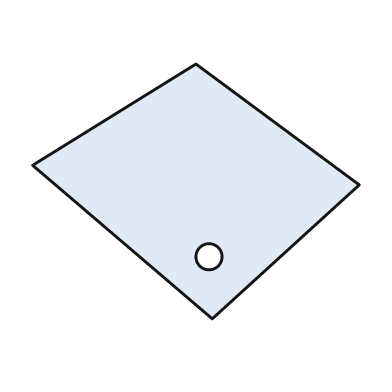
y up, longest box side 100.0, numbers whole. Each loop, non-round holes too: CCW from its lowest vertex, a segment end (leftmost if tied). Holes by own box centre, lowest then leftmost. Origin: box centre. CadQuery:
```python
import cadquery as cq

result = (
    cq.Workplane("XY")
    .moveTo(5.0, -39.0)
    .lineTo(50.0, 2.0)
    .lineTo(0.0, 39.0)
    .lineTo(-50.0, 8.0)
    .close()
    .moveTo(4.0, -20.0)
    .circle(4.0)
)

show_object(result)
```